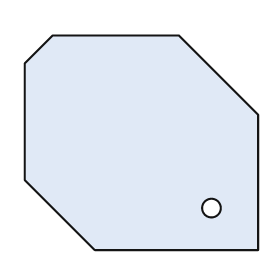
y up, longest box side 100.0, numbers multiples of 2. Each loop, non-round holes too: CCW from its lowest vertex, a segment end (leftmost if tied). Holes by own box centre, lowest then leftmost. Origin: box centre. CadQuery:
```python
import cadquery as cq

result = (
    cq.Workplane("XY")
    .moveTo(-20.0, -46.0)
    .lineTo(50.0, -46.0)
    .lineTo(50.0, 12.0)
    .lineTo(16.0, 46.0)
    .lineTo(-38.0, 46.0)
    .lineTo(-50.0, 34.0)
    .lineTo(-50.0, -16.0)
    .close()
    .moveTo(30.0, -28.0)
    .circle(4.0)
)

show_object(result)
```